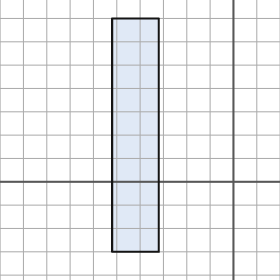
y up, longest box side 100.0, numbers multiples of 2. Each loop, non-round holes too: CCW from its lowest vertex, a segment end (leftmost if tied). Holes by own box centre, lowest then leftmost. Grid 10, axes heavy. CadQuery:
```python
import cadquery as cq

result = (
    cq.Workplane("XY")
    .moveTo(-52.0, -30.0)
    .lineTo(-32.0, -30.0)
    .lineTo(-32.0, 70.0)
    .lineTo(-52.0, 70.0)
    .close()
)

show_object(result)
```